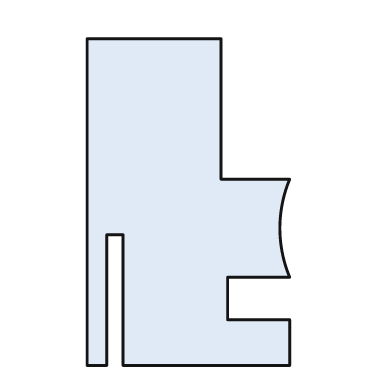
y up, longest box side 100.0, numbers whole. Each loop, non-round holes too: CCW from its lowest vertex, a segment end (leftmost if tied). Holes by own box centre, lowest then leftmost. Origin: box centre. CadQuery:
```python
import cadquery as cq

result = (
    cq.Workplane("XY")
    .moveTo(-31.0, -50.0)
    .lineTo(-25.0, -50.0)
    .lineTo(-25.0, -10.0)
    .lineTo(-20.0, -10.0)
    .lineTo(-20.0, -50.0)
    .lineTo(31.0, -50.0)
    .lineTo(31.0, -36.0)
    .lineTo(12.0, -36.0)
    .lineTo(12.0, -23.0)
    .lineTo(31.0, -23.0)
    .threePointArc((28.0, -8.0), (31.0, 7.0))
    .lineTo(10.0, 7.0)
    .lineTo(10.0, 50.0)
    .lineTo(-31.0, 50.0)
    .close()
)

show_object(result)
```